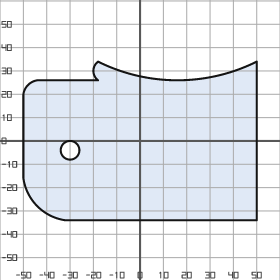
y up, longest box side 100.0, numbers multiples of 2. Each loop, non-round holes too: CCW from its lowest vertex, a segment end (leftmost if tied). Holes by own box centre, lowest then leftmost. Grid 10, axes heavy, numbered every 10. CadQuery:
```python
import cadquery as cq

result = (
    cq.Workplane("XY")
    .moveTo(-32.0, -34.0)
    .lineTo(50.0, -34.0)
    .lineTo(50.0, 34.0)
    .threePointArc((16.0, 26.0), (-18.0, 34.0))
    .threePointArc((-20.0, 30.0), (-18.0, 26.0))
    .lineTo(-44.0, 26.0)
    .threePointArc((-48.0, 24.0), (-50.0, 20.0))
    .lineTo(-50.0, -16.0)
    .threePointArc((-44.0, -28.0), (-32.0, -34.0))
    .close()
    .moveTo(-30.0, -4.0)
    .circle(4.0)
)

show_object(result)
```